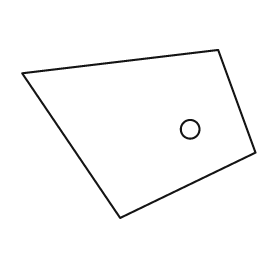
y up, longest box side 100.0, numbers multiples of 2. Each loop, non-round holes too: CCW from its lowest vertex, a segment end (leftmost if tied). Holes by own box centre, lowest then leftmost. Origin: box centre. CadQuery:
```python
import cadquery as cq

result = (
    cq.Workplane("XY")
    .moveTo(-8.0, -36.0)
    .lineTo(50.0, -8.0)
    .lineTo(34.0, 36.0)
    .lineTo(-50.0, 26.0)
    .close()
    .moveTo(22.0, 2.0)
    .circle(4.0)
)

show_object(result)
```